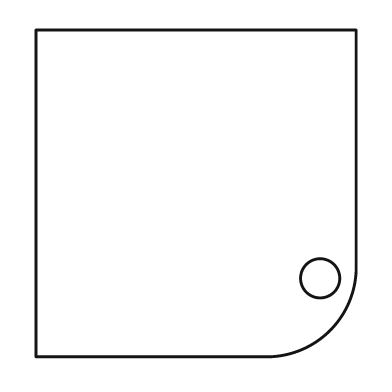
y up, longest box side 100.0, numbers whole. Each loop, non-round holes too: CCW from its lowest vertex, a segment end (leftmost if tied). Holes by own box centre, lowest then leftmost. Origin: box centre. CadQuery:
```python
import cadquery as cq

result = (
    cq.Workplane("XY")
    .moveTo(-49.0, -50.0)
    .lineTo(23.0, -50.0)
    .threePointArc((41.0, -42.0), (49.0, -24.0))
    .lineTo(49.0, 50.0)
    .lineTo(-49.0, 50.0)
    .close()
    .moveTo(38.0, -26.0)
    .circle(6.0)
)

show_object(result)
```